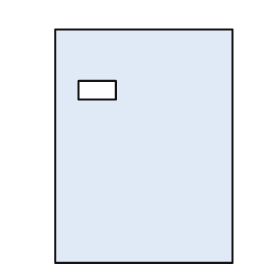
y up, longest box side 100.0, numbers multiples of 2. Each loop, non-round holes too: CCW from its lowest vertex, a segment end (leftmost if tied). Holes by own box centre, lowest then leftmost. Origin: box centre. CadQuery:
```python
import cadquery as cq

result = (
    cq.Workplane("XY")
    .moveTo(-38.0, -50.0)
    .lineTo(38.0, -50.0)
    .lineTo(38.0, 50.0)
    .lineTo(-38.0, 50.0)
    .close()
    .moveTo(-28.0, 20.0)
    .lineTo(-12.0, 20.0)
    .lineTo(-12.0, 28.0)
    .lineTo(-28.0, 28.0)
    .close()
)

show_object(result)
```